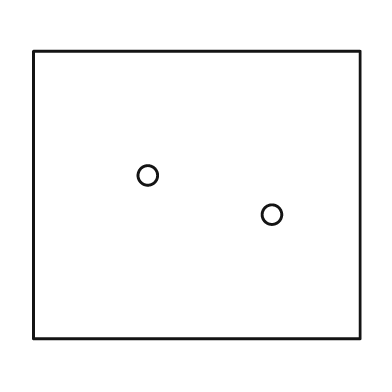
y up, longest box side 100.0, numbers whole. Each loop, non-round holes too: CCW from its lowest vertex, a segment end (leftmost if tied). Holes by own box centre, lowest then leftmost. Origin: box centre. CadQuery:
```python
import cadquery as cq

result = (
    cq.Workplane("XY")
    .moveTo(-50.0, -44.0)
    .lineTo(50.0, -44.0)
    .lineTo(50.0, 44.0)
    .lineTo(-50.0, 44.0)
    .close()
    .moveTo(23.0, -6.0)
    .circle(3.0)
    .moveTo(-15.0, 6.0)
    .circle(3.0)
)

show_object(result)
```